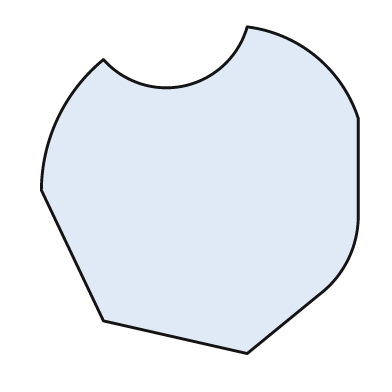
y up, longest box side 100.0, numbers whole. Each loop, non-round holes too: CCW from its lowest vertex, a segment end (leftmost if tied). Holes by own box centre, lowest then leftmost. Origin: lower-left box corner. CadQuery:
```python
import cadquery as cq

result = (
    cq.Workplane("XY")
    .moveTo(63.0, 0.0)
    .lineTo(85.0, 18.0)
    .threePointArc((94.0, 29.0), (97.0, 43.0))
    .lineTo(97.0, 72.0)
    .threePointArc((84.0, 91.0), (63.0, 100.0))
    .threePointArc((44.0, 82.0), (19.0, 90.0))
    .threePointArc((5.0, 72.0), (0.0, 50.0))
    .lineTo(19.0, 10.0)
    .close()
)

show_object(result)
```